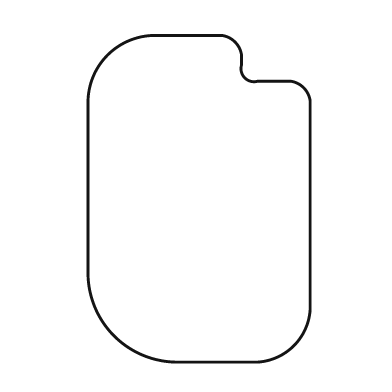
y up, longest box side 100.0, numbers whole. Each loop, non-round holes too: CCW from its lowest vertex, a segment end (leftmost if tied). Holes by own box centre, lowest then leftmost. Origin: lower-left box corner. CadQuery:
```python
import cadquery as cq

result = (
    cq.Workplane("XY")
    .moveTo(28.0, 0.0)
    .lineTo(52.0, 0.0)
    .threePointArc((63.0, 5.0), (68.0, 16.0))
    .lineTo(68.0, 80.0)
    .threePointArc((66.0, 84.0), (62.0, 86.0))
    .lineTo(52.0, 86.0)
    .threePointArc((48.0, 87.0), (47.0, 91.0))
    .lineTo(47.0, 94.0)
    .threePointArc((45.0, 98.0), (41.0, 100.0))
    .lineTo(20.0, 100.0)
    .threePointArc((6.0, 94.0), (0.0, 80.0))
    .lineTo(0.0, 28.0)
    .threePointArc((8.0, 8.0), (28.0, 0.0))
    .close()
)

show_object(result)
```